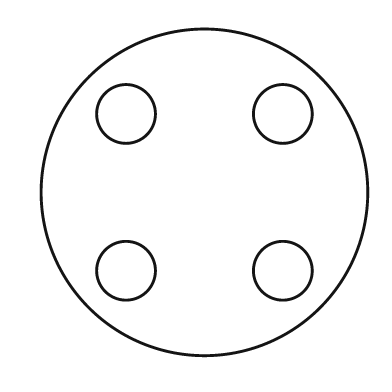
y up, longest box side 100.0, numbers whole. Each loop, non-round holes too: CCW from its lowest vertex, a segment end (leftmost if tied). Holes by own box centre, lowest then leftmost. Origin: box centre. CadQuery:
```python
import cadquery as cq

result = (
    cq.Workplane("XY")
    .moveTo(0.0, 0.0)
    .circle(50.0)
    .moveTo(-24.0, -24.0)
    .circle(9.0)
    .moveTo(24.0, -24.0)
    .circle(9.0)
    .moveTo(-24.0, 24.0)
    .circle(9.0)
    .moveTo(24.0, 24.0)
    .circle(9.0)
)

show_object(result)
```